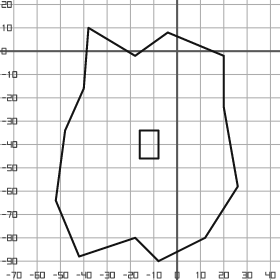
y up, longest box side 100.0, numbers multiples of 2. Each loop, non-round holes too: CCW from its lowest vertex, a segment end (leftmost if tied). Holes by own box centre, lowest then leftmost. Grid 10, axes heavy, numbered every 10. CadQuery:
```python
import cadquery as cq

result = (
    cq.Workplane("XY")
    .moveTo(-8.0, -90.0)
    .lineTo(12.0, -80.0)
    .lineTo(26.0, -58.0)
    .lineTo(20.0, -24.0)
    .lineTo(20.0, -2.0)
    .lineTo(-4.0, 8.0)
    .lineTo(-18.0, -2.0)
    .lineTo(-38.0, 10.0)
    .lineTo(-40.0, -16.0)
    .lineTo(-48.0, -34.0)
    .lineTo(-52.0, -64.0)
    .lineTo(-42.0, -88.0)
    .lineTo(-18.0, -80.0)
    .close()
    .moveTo(-16.0, -46.0)
    .lineTo(-8.0, -46.0)
    .lineTo(-8.0, -34.0)
    .lineTo(-16.0, -34.0)
    .close()
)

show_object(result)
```